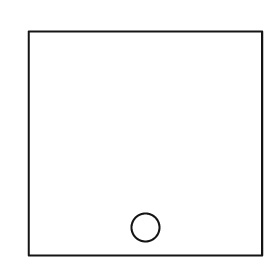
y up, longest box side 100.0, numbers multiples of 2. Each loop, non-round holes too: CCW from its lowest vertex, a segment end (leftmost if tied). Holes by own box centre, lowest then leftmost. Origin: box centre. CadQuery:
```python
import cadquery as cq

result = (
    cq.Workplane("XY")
    .moveTo(-50.0, -48.0)
    .lineTo(50.0, -48.0)
    .lineTo(50.0, 48.0)
    .lineTo(-50.0, 48.0)
    .close()
    .moveTo(0.0, -36.0)
    .circle(6.0)
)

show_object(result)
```